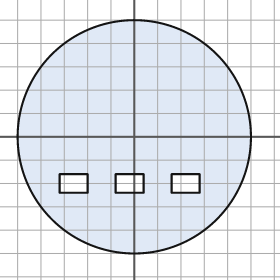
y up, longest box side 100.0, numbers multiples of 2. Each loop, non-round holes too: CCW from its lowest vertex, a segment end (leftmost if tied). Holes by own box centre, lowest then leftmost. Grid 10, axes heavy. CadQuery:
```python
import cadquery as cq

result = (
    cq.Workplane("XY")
    .moveTo(0.0, 0.0)
    .circle(50.0)
    .moveTo(-32.0, -24.0)
    .lineTo(-20.0, -24.0)
    .lineTo(-20.0, -16.0)
    .lineTo(-32.0, -16.0)
    .close()
    .moveTo(-8.0, -24.0)
    .lineTo(4.0, -24.0)
    .lineTo(4.0, -16.0)
    .lineTo(-8.0, -16.0)
    .close()
    .moveTo(16.0, -24.0)
    .lineTo(28.0, -24.0)
    .lineTo(28.0, -16.0)
    .lineTo(16.0, -16.0)
    .close()
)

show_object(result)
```